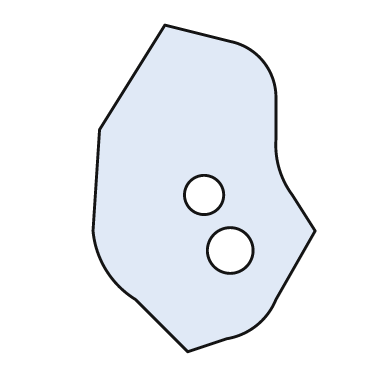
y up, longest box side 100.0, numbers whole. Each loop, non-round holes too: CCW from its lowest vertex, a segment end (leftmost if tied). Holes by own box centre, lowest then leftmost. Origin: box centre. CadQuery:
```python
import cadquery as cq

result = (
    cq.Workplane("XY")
    .moveTo(-5.0, -50.0)
    .lineTo(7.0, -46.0)
    .threePointArc((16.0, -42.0), (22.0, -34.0))
    .lineTo(34.0, -13.0)
    .lineTo(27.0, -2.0)
    .threePointArc((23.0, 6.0), (22.0, 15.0))
    .lineTo(22.0, 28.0)
    .threePointArc((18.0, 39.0), (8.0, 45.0))
    .lineTo(-12.0, 50.0)
    .lineTo(-32.0, 18.0)
    .lineTo(-34.0, -13.0)
    .threePointArc((-30.0, -25.0), (-21.0, -34.0))
    .close()
    .moveTo(8.0, -19.0)
    .circle(7.0)
    .moveTo(0.0, -2.0)
    .circle(6.0)
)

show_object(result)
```